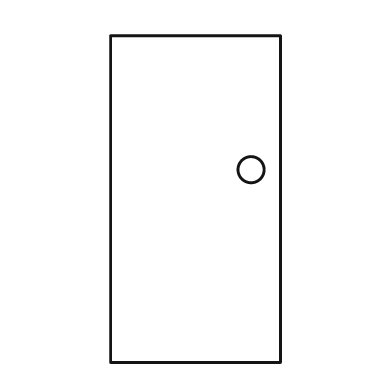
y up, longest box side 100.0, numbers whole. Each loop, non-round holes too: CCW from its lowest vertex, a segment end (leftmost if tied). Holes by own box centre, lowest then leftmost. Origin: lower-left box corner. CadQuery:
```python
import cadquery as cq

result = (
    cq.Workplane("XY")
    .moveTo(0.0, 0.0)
    .lineTo(52.0, 0.0)
    .lineTo(52.0, 100.0)
    .lineTo(0.0, 100.0)
    .close()
    .moveTo(43.0, 59.0)
    .circle(4.0)
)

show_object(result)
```